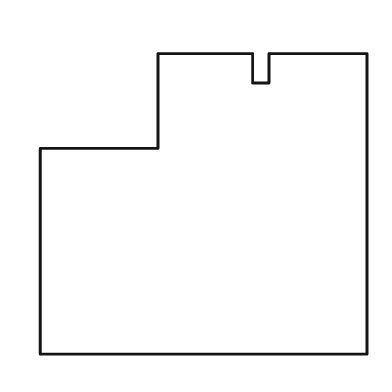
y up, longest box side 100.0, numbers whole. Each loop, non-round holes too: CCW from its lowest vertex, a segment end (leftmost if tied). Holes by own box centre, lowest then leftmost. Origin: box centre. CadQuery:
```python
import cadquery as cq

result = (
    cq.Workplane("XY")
    .moveTo(-50.0, -46.0)
    .lineTo(50.0, -46.0)
    .lineTo(50.0, 46.0)
    .lineTo(20.0, 46.0)
    .lineTo(20.0, 37.0)
    .lineTo(15.0, 37.0)
    .lineTo(15.0, 46.0)
    .lineTo(-14.0, 46.0)
    .lineTo(-14.0, 17.0)
    .lineTo(-50.0, 17.0)
    .close()
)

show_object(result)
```